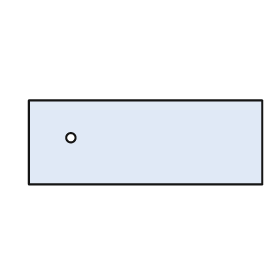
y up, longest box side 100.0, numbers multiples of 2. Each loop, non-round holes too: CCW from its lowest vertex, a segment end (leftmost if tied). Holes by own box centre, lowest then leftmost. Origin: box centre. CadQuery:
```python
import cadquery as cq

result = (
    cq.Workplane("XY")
    .moveTo(-50.0, -18.0)
    .lineTo(50.0, -18.0)
    .lineTo(50.0, 18.0)
    .lineTo(-50.0, 18.0)
    .close()
    .moveTo(-32.0, 2.0)
    .circle(2.0)
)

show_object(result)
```